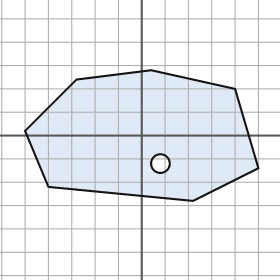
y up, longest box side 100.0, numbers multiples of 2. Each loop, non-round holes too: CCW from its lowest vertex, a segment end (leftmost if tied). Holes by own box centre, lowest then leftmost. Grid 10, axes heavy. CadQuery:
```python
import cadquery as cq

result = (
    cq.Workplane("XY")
    .moveTo(22.0, -28.0)
    .lineTo(50.0, -14.0)
    .lineTo(40.0, 20.0)
    .lineTo(4.0, 28.0)
    .lineTo(-28.0, 24.0)
    .lineTo(-50.0, 2.0)
    .lineTo(-40.0, -22.0)
    .close()
    .moveTo(8.0, -12.0)
    .circle(4.0)
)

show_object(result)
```